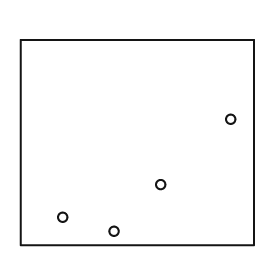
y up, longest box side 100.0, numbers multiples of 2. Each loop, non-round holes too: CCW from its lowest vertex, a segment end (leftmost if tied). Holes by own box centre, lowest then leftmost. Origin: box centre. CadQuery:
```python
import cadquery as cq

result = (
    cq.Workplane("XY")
    .moveTo(-50.0, -44.0)
    .lineTo(50.0, -44.0)
    .lineTo(50.0, 44.0)
    .lineTo(-50.0, 44.0)
    .close()
    .moveTo(-10.0, -38.0)
    .circle(2.0)
    .moveTo(-32.0, -32.0)
    .circle(2.0)
    .moveTo(10.0, -18.0)
    .circle(2.0)
    .moveTo(40.0, 10.0)
    .circle(2.0)
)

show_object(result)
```